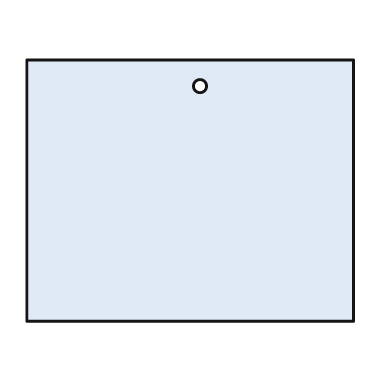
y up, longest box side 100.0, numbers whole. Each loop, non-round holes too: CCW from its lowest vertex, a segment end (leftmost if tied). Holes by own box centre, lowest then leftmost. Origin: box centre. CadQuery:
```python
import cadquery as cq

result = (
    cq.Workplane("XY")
    .moveTo(-50.0, -40.0)
    .lineTo(50.0, -40.0)
    .lineTo(50.0, 40.0)
    .lineTo(-50.0, 40.0)
    .close()
    .moveTo(3.0, 32.0)
    .circle(2.0)
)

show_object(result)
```